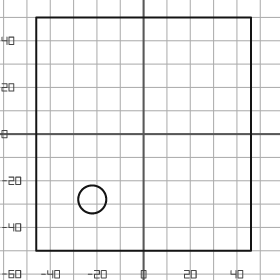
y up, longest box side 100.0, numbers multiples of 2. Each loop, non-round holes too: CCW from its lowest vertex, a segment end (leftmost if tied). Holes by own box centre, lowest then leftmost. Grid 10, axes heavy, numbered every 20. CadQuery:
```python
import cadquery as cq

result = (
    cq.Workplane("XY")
    .moveTo(-46.0, -50.0)
    .lineTo(46.0, -50.0)
    .lineTo(46.0, 50.0)
    .lineTo(-46.0, 50.0)
    .close()
    .moveTo(-22.0, -28.0)
    .circle(6.0)
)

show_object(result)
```